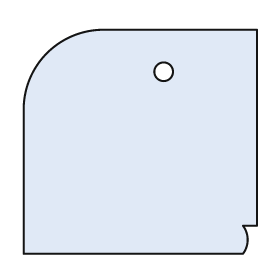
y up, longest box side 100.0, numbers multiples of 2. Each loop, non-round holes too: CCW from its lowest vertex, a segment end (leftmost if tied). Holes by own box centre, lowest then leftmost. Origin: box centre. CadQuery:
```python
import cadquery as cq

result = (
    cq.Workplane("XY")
    .moveTo(-50.0, -48.0)
    .lineTo(44.0, -48.0)
    .threePointArc((46.0, -42.0), (44.0, -36.0))
    .lineTo(50.0, -36.0)
    .lineTo(50.0, 48.0)
    .lineTo(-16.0, 48.0)
    .threePointArc((-40.0, 38.0), (-50.0, 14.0))
    .close()
    .moveTo(10.0, 30.0)
    .circle(4.0)
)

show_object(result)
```